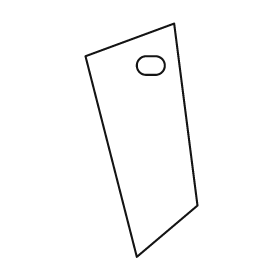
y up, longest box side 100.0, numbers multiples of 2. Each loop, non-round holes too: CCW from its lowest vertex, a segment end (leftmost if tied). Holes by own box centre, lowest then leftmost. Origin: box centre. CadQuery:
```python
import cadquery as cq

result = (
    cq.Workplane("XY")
    .moveTo(-2.0, -50.0)
    .lineTo(24.0, -28.0)
    .lineTo(14.0, 50.0)
    .lineTo(-24.0, 36.0)
    .close()
    .moveTo(2.0, 28.0)
    .lineTo(6.0, 28.0)
    .threePointArc((10.0, 32.0), (6.0, 36.0))
    .lineTo(2.0, 36.0)
    .threePointArc((-2.0, 32.0), (2.0, 28.0))
    .close()
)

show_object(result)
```